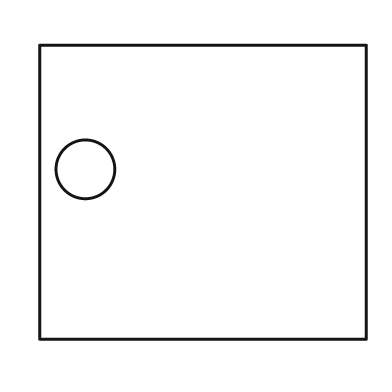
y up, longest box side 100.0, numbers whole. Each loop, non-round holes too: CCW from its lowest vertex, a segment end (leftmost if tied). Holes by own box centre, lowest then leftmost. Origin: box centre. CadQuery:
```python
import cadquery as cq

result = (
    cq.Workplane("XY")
    .moveTo(-50.0, -45.0)
    .lineTo(50.0, -45.0)
    .lineTo(50.0, 45.0)
    .lineTo(-50.0, 45.0)
    .close()
    .moveTo(-36.0, 7.0)
    .circle(9.0)
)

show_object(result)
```